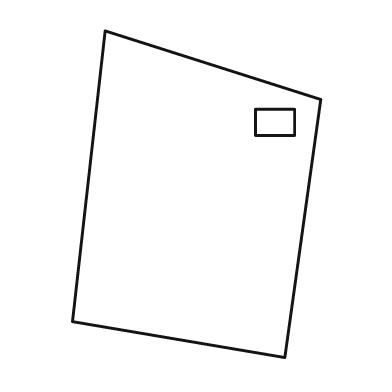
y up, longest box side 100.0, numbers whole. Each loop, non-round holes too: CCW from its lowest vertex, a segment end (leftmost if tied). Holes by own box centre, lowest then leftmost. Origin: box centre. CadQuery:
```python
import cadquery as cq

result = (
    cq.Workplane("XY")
    .moveTo(27.0, -50.0)
    .lineTo(38.0, 29.0)
    .lineTo(-28.0, 50.0)
    .lineTo(-38.0, -39.0)
    .close()
    .moveTo(18.0, 18.0)
    .lineTo(30.0, 18.0)
    .lineTo(30.0, 26.0)
    .lineTo(18.0, 26.0)
    .close()
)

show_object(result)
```